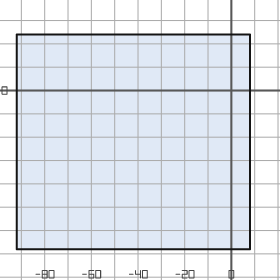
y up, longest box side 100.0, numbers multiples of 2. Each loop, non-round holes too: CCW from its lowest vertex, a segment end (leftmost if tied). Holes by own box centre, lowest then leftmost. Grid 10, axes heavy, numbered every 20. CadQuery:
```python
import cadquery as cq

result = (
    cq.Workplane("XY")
    .moveTo(-92.0, -68.0)
    .lineTo(8.0, -68.0)
    .lineTo(8.0, 24.0)
    .lineTo(-92.0, 24.0)
    .close()
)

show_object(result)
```